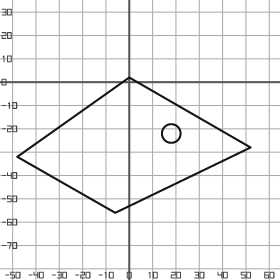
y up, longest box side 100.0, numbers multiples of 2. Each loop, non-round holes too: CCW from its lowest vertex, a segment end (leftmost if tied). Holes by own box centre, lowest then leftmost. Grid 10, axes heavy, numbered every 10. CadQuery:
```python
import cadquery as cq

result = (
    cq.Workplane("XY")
    .moveTo(-6.0, -56.0)
    .lineTo(52.0, -28.0)
    .lineTo(0.0, 2.0)
    .lineTo(-48.0, -32.0)
    .close()
    .moveTo(18.0, -22.0)
    .circle(4.0)
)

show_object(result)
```